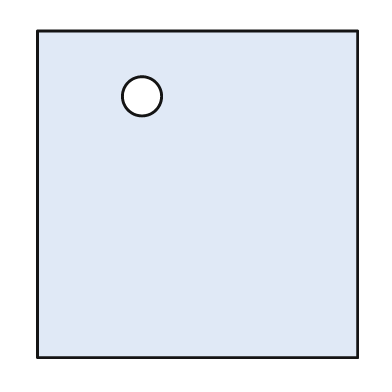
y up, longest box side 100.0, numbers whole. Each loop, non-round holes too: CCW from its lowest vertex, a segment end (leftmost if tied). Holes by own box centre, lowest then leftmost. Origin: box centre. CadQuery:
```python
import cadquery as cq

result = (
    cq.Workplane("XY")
    .moveTo(-49.0, -50.0)
    .lineTo(49.0, -50.0)
    .lineTo(49.0, 50.0)
    .lineTo(-49.0, 50.0)
    .close()
    .moveTo(-17.0, 30.0)
    .circle(6.0)
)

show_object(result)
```